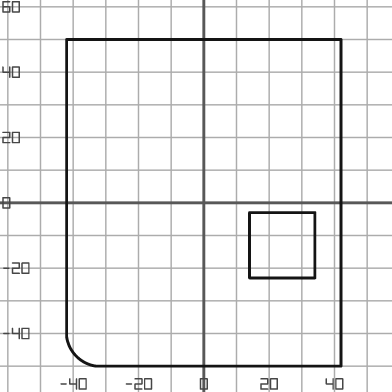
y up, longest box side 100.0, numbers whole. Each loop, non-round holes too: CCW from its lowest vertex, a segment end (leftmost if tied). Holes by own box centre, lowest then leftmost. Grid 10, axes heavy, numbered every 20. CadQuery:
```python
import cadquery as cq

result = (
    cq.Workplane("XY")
    .moveTo(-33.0, -50.0)
    .lineTo(42.0, -50.0)
    .lineTo(42.0, 50.0)
    .lineTo(-42.0, 50.0)
    .lineTo(-42.0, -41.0)
    .threePointArc((-39.0, -47.0), (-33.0, -50.0))
    .close()
    .moveTo(14.0, -23.0)
    .lineTo(34.0, -23.0)
    .lineTo(34.0, -3.0)
    .lineTo(14.0, -3.0)
    .close()
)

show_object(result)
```